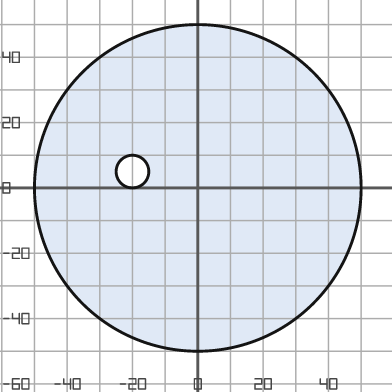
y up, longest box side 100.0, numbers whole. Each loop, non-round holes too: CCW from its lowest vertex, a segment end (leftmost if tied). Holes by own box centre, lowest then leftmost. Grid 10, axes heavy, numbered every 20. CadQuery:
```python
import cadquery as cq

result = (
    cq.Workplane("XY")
    .moveTo(0.0, 0.0)
    .circle(50.0)
    .moveTo(-20.0, 5.0)
    .circle(5.0)
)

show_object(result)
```